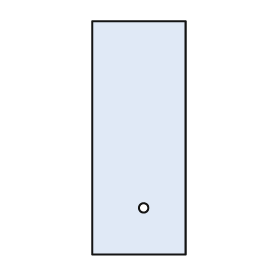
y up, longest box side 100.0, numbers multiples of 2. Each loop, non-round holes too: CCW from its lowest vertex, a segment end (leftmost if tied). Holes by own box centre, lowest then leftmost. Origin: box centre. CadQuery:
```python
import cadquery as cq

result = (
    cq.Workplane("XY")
    .moveTo(-20.0, -50.0)
    .lineTo(20.0, -50.0)
    .lineTo(20.0, 50.0)
    .lineTo(-20.0, 50.0)
    .close()
    .moveTo(2.0, -30.0)
    .circle(2.0)
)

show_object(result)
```